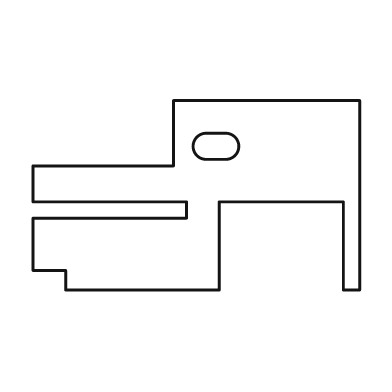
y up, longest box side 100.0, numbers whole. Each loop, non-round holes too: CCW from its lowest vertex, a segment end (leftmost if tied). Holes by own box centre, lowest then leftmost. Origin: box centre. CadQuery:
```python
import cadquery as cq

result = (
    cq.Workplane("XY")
    .moveTo(-40.0, -29.0)
    .lineTo(7.0, -29.0)
    .lineTo(7.0, -2.0)
    .lineTo(45.0, -2.0)
    .lineTo(45.0, -29.0)
    .lineTo(50.0, -29.0)
    .lineTo(50.0, 29.0)
    .lineTo(-7.0, 29.0)
    .lineTo(-7.0, 9.0)
    .lineTo(-50.0, 9.0)
    .lineTo(-50.0, -2.0)
    .lineTo(-3.0, -2.0)
    .lineTo(-3.0, -7.0)
    .lineTo(-50.0, -7.0)
    .lineTo(-50.0, -23.0)
    .lineTo(-40.0, -23.0)
    .close()
    .moveTo(3.0, 11.0)
    .lineTo(9.0, 11.0)
    .threePointArc((13.0, 15.0), (9.0, 19.0))
    .lineTo(3.0, 19.0)
    .threePointArc((-1.0, 15.0), (3.0, 11.0))
    .close()
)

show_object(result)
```